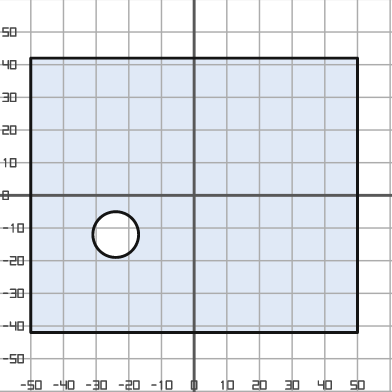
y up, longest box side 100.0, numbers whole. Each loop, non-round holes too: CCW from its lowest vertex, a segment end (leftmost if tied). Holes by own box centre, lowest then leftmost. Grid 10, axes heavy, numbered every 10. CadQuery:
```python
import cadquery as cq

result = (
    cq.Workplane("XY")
    .moveTo(-50.0, -42.0)
    .lineTo(50.0, -42.0)
    .lineTo(50.0, 42.0)
    .lineTo(-50.0, 42.0)
    .close()
    .moveTo(-24.0, -12.0)
    .circle(7.0)
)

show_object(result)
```